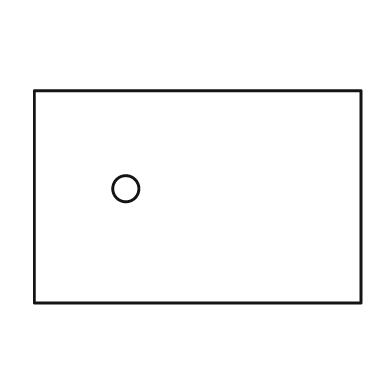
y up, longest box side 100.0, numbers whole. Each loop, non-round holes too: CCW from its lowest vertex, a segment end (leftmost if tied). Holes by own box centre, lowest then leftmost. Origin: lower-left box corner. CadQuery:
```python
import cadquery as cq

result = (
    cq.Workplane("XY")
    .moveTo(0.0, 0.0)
    .lineTo(100.0, 0.0)
    .lineTo(100.0, 65.0)
    .lineTo(0.0, 65.0)
    .close()
    .moveTo(28.0, 35.0)
    .circle(4.0)
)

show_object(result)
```